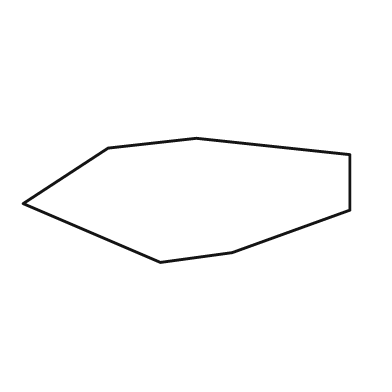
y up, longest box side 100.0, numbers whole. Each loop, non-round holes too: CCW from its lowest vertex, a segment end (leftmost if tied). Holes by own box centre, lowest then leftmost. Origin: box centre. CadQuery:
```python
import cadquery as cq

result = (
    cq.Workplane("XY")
    .moveTo(-8.0, -19.0)
    .lineTo(14.0, -16.0)
    .lineTo(50.0, -3.0)
    .lineTo(50.0, 14.0)
    .lineTo(3.0, 19.0)
    .lineTo(-24.0, 16.0)
    .lineTo(-50.0, -1.0)
    .close()
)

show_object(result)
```